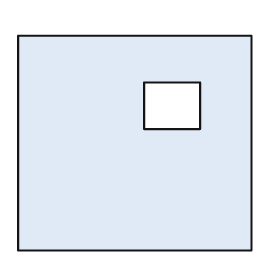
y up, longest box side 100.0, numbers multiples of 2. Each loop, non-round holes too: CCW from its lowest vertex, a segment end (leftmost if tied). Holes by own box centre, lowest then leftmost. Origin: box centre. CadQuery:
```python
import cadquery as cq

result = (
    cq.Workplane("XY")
    .moveTo(-50.0, -46.0)
    .lineTo(50.0, -46.0)
    .lineTo(50.0, 46.0)
    .lineTo(-50.0, 46.0)
    .close()
    .moveTo(4.0, 6.0)
    .lineTo(28.0, 6.0)
    .lineTo(28.0, 26.0)
    .lineTo(4.0, 26.0)
    .close()
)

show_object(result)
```